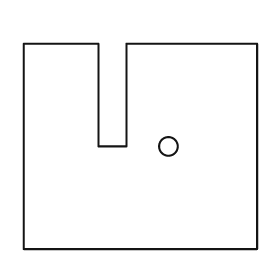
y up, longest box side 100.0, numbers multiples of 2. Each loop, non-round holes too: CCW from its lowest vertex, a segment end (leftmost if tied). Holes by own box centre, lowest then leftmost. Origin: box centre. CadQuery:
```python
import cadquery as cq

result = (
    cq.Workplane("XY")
    .moveTo(-50.0, -44.0)
    .lineTo(50.0, -44.0)
    .lineTo(50.0, 44.0)
    .lineTo(-6.0, 44.0)
    .lineTo(-6.0, 0.0)
    .lineTo(-18.0, 0.0)
    .lineTo(-18.0, 44.0)
    .lineTo(-50.0, 44.0)
    .close()
    .moveTo(12.0, 0.0)
    .circle(4.0)
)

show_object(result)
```